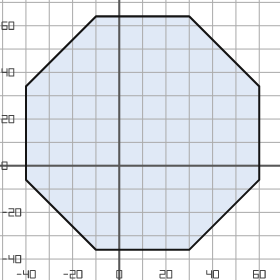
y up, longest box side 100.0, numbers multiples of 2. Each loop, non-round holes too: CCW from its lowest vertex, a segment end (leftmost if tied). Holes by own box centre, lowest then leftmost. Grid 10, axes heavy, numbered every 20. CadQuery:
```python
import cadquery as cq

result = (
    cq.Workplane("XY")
    .moveTo(-10.0, -36.0)
    .lineTo(30.0, -36.0)
    .lineTo(60.0, -6.0)
    .lineTo(60.0, 34.0)
    .lineTo(30.0, 64.0)
    .lineTo(-10.0, 64.0)
    .lineTo(-40.0, 34.0)
    .lineTo(-40.0, -6.0)
    .close()
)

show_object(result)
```